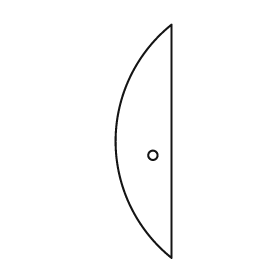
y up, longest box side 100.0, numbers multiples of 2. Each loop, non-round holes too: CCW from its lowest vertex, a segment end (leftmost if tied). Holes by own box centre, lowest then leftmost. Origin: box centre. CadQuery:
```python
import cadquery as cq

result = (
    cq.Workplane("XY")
    .moveTo(12.0, -50.0)
    .lineTo(12.0, 50.0)
    .threePointArc((-12.0, 0.0), (12.0, -50.0))
    .close()
    .moveTo(4.0, -6.0)
    .circle(2.0)
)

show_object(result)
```